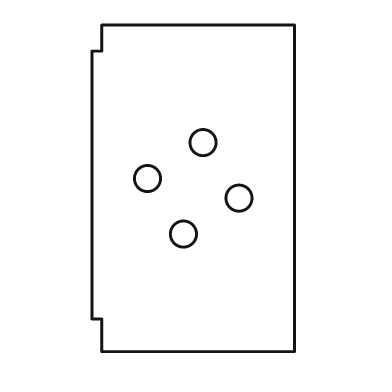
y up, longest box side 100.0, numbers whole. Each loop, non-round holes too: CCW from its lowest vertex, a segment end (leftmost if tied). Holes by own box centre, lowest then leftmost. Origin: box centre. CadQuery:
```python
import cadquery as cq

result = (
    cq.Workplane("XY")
    .moveTo(-28.0, -50.0)
    .lineTo(31.0, -50.0)
    .lineTo(31.0, 50.0)
    .lineTo(-28.0, 50.0)
    .lineTo(-28.0, 42.0)
    .lineTo(-31.0, 42.0)
    .lineTo(-31.0, -40.0)
    .lineTo(-28.0, -40.0)
    .close()
    .moveTo(-3.0, -14.0)
    .circle(4.0)
    .moveTo(14.0, -3.0)
    .circle(4.0)
    .moveTo(-14.0, 3.0)
    .circle(4.0)
    .moveTo(3.0, 14.0)
    .circle(4.0)
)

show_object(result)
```